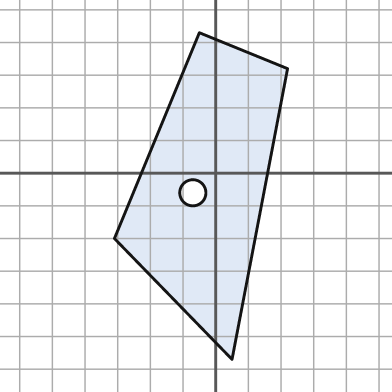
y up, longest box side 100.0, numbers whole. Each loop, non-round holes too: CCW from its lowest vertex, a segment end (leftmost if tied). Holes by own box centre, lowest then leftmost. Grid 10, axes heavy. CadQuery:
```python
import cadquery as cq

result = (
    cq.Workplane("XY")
    .moveTo(5.0, -57.0)
    .lineTo(22.0, 32.0)
    .lineTo(-5.0, 43.0)
    .lineTo(-31.0, -20.0)
    .close()
    .moveTo(-7.0, -6.0)
    .circle(4.0)
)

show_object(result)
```